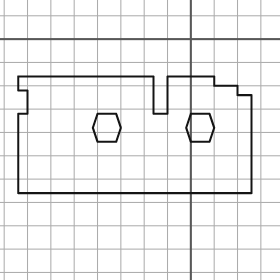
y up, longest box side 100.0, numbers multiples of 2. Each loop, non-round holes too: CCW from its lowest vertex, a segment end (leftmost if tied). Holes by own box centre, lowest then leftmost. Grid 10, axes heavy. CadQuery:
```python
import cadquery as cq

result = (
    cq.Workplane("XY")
    .moveTo(-74.0, -66.0)
    .lineTo(26.0, -66.0)
    .lineTo(26.0, -24.0)
    .lineTo(20.0, -24.0)
    .lineTo(20.0, -20.0)
    .lineTo(10.0, -20.0)
    .lineTo(10.0, -16.0)
    .lineTo(-10.0, -16.0)
    .lineTo(-10.0, -32.0)
    .lineTo(-16.0, -32.0)
    .lineTo(-16.0, -16.0)
    .lineTo(-74.0, -16.0)
    .lineTo(-74.0, -22.0)
    .lineTo(-70.0, -22.0)
    .lineTo(-70.0, -32.0)
    .lineTo(-74.0, -32.0)
    .close()
    .moveTo(-40.0, -44.0)
    .lineTo(-32.0, -44.0)
    .lineTo(-30.0, -38.0)
    .lineTo(-32.0, -32.0)
    .lineTo(-40.0, -32.0)
    .lineTo(-42.0, -38.0)
    .close()
    .moveTo(0.0, -44.0)
    .lineTo(8.0, -44.0)
    .lineTo(10.0, -38.0)
    .lineTo(8.0, -32.0)
    .lineTo(0.0, -32.0)
    .lineTo(-2.0, -38.0)
    .close()
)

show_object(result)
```